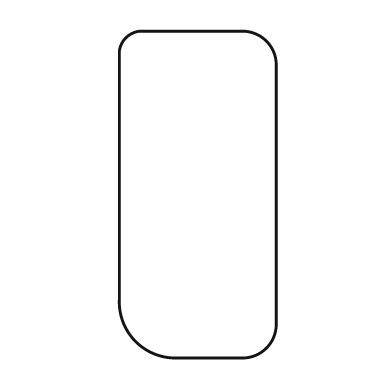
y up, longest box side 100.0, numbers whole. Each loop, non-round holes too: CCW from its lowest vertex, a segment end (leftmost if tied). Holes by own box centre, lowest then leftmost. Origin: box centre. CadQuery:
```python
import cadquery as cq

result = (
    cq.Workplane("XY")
    .moveTo(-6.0, -50.0)
    .lineTo(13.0, -50.0)
    .threePointArc((21.0, -47.0), (24.0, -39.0))
    .lineTo(24.0, 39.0)
    .threePointArc((21.0, 47.0), (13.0, 50.0))
    .lineTo(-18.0, 50.0)
    .threePointArc((-22.0, 48.0), (-24.0, 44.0))
    .lineTo(-24.0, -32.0)
    .threePointArc((-19.0, -45.0), (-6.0, -50.0))
    .close()
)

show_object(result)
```